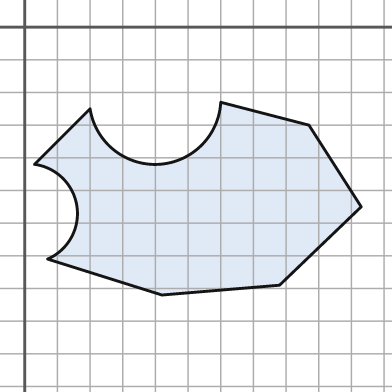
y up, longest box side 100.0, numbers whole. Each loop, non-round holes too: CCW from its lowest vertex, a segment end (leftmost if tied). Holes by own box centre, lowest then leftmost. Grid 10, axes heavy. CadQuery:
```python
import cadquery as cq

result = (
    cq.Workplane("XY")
    .moveTo(42.0, -82.0)
    .lineTo(78.0, -79.0)
    .lineTo(103.0, -55.0)
    .lineTo(87.0, -30.0)
    .lineTo(60.0, -23.0)
    .threePointArc((41.0, -42.0), (20.0, -25.0))
    .lineTo(3.0, -42.0)
    .threePointArc((16.0, -55.0), (7.0, -71.0))
    .close()
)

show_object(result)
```